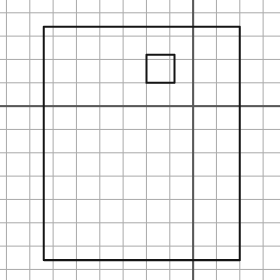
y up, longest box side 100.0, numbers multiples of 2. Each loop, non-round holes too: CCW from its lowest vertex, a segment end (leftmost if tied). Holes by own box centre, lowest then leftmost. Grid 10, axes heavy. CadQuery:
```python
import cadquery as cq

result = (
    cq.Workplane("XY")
    .moveTo(-64.0, -66.0)
    .lineTo(20.0, -66.0)
    .lineTo(20.0, 34.0)
    .lineTo(-64.0, 34.0)
    .close()
    .moveTo(-20.0, 10.0)
    .lineTo(-8.0, 10.0)
    .lineTo(-8.0, 22.0)
    .lineTo(-20.0, 22.0)
    .close()
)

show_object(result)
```